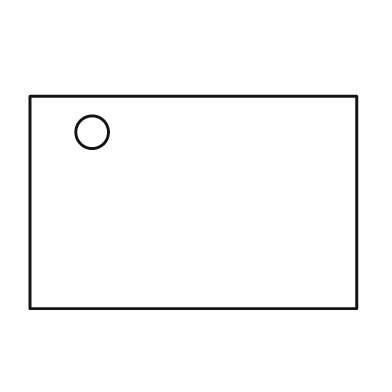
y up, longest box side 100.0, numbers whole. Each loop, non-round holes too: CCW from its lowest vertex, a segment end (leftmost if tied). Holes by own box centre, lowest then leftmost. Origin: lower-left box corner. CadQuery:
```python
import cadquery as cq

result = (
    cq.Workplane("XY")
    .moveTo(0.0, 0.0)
    .lineTo(100.0, 0.0)
    .lineTo(100.0, 65.0)
    .lineTo(0.0, 65.0)
    .close()
    .moveTo(19.0, 54.0)
    .circle(5.0)
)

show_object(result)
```